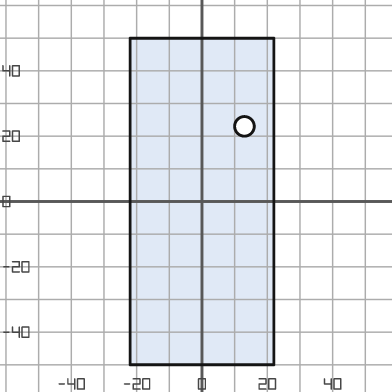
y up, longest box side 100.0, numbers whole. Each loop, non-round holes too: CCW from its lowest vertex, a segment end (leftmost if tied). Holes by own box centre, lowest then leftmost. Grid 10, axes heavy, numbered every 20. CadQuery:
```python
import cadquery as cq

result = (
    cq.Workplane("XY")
    .moveTo(-22.0, -50.0)
    .lineTo(22.0, -50.0)
    .lineTo(22.0, 50.0)
    .lineTo(-22.0, 50.0)
    .close()
    .moveTo(13.0, 23.0)
    .circle(3.0)
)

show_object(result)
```